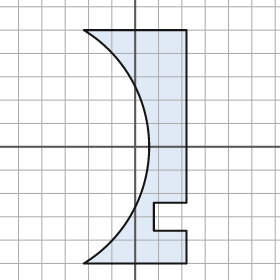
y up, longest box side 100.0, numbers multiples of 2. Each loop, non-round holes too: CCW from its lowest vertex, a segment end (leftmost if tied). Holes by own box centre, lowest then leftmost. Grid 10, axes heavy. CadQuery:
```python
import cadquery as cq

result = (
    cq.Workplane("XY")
    .moveTo(-22.0, -50.0)
    .lineTo(22.0, -50.0)
    .lineTo(22.0, -36.0)
    .lineTo(8.0, -36.0)
    .lineTo(8.0, -24.0)
    .lineTo(22.0, -24.0)
    .lineTo(22.0, 50.0)
    .lineTo(-22.0, 50.0)
    .threePointArc((6.0, 0.0), (-22.0, -50.0))
    .close()
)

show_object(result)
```